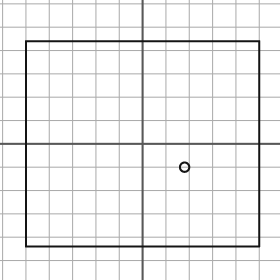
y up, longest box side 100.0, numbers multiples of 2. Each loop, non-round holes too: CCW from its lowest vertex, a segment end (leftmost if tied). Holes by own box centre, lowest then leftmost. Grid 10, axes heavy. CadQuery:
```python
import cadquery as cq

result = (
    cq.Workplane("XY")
    .moveTo(-50.0, -44.0)
    .lineTo(50.0, -44.0)
    .lineTo(50.0, 44.0)
    .lineTo(-50.0, 44.0)
    .close()
    .moveTo(18.0, -10.0)
    .circle(2.0)
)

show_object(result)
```